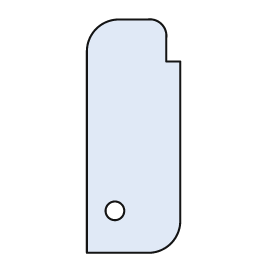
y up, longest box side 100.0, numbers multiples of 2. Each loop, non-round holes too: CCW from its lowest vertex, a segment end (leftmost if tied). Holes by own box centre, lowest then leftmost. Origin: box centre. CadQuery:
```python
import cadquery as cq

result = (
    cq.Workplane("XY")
    .moveTo(-20.0, -50.0)
    .lineTo(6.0, -50.0)
    .threePointArc((16.0, -46.0), (20.0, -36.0))
    .lineTo(20.0, 32.0)
    .lineTo(14.0, 32.0)
    .lineTo(14.0, 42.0)
    .threePointArc((12.0, 48.0), (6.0, 50.0))
    .lineTo(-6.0, 50.0)
    .threePointArc((-16.0, 46.0), (-20.0, 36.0))
    .close()
    .moveTo(-8.0, -32.0)
    .circle(4.0)
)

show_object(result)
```